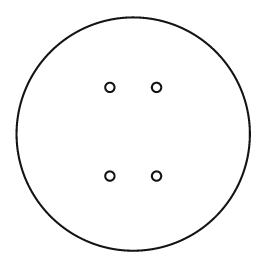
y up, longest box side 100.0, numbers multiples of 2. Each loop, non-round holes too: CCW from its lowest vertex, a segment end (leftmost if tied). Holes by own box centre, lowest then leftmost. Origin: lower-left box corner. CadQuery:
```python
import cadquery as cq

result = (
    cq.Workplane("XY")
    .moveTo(50.0, 50.0)
    .circle(50.0)
    .moveTo(40.0, 32.0)
    .circle(2.0)
    .moveTo(60.0, 32.0)
    .circle(2.0)
    .moveTo(40.0, 70.0)
    .circle(2.0)
    .moveTo(60.0, 70.0)
    .circle(2.0)
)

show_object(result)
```